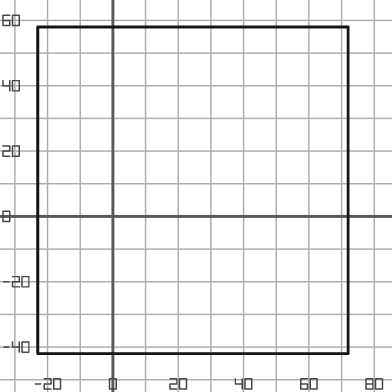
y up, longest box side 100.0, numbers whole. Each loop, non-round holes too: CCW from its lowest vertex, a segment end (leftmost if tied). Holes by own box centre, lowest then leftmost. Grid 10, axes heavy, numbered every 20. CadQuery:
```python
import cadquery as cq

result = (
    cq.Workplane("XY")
    .moveTo(-23.0, -42.0)
    .lineTo(72.0, -42.0)
    .lineTo(72.0, 58.0)
    .lineTo(-23.0, 58.0)
    .close()
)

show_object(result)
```